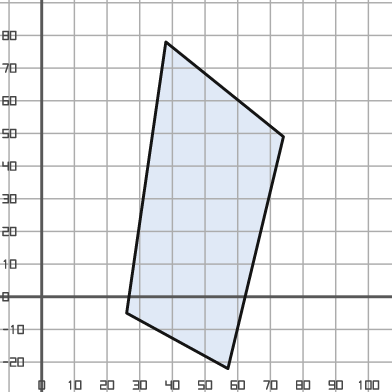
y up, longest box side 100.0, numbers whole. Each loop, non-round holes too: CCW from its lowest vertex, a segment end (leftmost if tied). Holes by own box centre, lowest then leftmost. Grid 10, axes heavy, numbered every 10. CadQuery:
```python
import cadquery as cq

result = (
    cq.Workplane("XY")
    .moveTo(57.0, -22.0)
    .lineTo(74.0, 49.0)
    .lineTo(38.0, 78.0)
    .lineTo(26.0, -5.0)
    .close()
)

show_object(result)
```